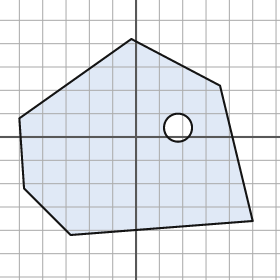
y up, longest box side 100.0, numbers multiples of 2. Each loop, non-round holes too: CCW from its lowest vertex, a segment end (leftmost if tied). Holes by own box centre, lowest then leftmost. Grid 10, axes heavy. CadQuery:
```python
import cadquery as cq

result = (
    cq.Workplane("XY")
    .moveTo(-28.0, -42.0)
    .lineTo(50.0, -36.0)
    .lineTo(36.0, 22.0)
    .lineTo(-2.0, 42.0)
    .lineTo(-50.0, 8.0)
    .lineTo(-48.0, -22.0)
    .close()
    .moveTo(18.0, 4.0)
    .circle(6.0)
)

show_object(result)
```